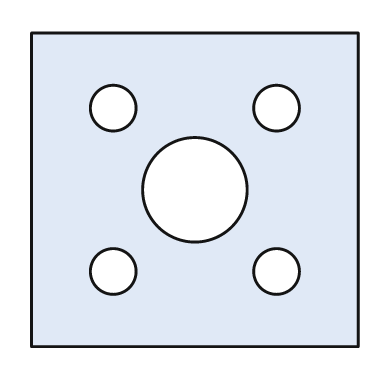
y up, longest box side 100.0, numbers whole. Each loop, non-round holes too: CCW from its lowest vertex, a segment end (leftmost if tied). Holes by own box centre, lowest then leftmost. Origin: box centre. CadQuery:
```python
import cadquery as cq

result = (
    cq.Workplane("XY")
    .moveTo(-50.0, -48.0)
    .lineTo(50.0, -48.0)
    .lineTo(50.0, 48.0)
    .lineTo(-50.0, 48.0)
    .close()
    .moveTo(-25.0, -25.0)
    .circle(7.0)
    .moveTo(25.0, -25.0)
    .circle(7.0)
    .moveTo(0.0, 0.0)
    .circle(16.0)
    .moveTo(-25.0, 25.0)
    .circle(7.0)
    .moveTo(25.0, 25.0)
    .circle(7.0)
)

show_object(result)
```